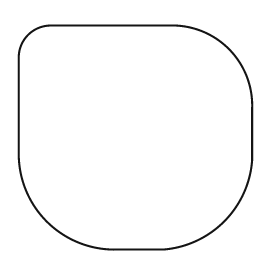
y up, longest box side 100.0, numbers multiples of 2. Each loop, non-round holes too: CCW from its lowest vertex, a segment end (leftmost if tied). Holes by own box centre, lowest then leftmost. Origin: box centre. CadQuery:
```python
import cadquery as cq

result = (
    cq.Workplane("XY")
    .moveTo(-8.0, -48.0)
    .lineTo(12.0, -48.0)
    .threePointArc((38.0, -36.0), (50.0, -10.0))
    .lineTo(50.0, 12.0)
    .threePointArc((40.0, 38.0), (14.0, 48.0))
    .lineTo(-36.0, 48.0)
    .threePointArc((-46.0, 44.0), (-50.0, 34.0))
    .lineTo(-50.0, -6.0)
    .threePointArc((-38.0, -36.0), (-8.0, -48.0))
    .close()
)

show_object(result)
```